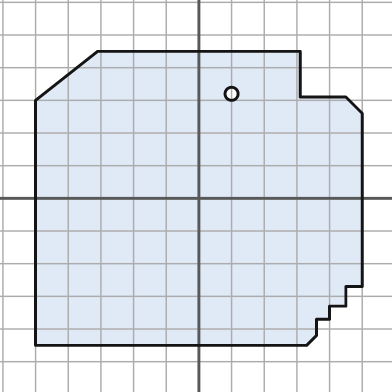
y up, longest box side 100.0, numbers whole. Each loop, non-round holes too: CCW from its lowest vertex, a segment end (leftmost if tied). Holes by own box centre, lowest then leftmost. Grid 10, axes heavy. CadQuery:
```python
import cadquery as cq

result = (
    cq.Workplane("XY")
    .moveTo(-50.0, -45.0)
    .lineTo(33.0, -45.0)
    .lineTo(36.0, -42.0)
    .lineTo(36.0, -37.0)
    .lineTo(40.0, -37.0)
    .lineTo(40.0, -33.0)
    .lineTo(45.0, -33.0)
    .lineTo(45.0, -27.0)
    .lineTo(50.0, -27.0)
    .lineTo(50.0, 26.0)
    .lineTo(45.0, 31.0)
    .lineTo(31.0, 31.0)
    .lineTo(31.0, 45.0)
    .lineTo(-31.0, 45.0)
    .lineTo(-50.0, 30.0)
    .close()
    .moveTo(10.0, 32.0)
    .circle(2.0)
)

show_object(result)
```